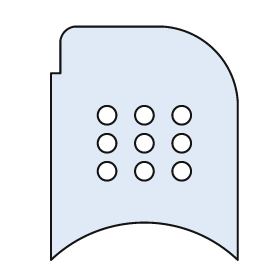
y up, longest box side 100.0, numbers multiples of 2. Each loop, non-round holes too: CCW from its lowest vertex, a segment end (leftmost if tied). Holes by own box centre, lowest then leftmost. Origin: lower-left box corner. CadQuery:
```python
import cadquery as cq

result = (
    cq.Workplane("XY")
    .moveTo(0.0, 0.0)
    .threePointArc((40.0, 16.0), (80.0, 0.0))
    .lineTo(80.0, 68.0)
    .threePointArc((70.0, 90.0), (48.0, 100.0))
    .lineTo(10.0, 100.0)
    .threePointArc((6.0, 98.0), (4.0, 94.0))
    .lineTo(4.0, 80.0)
    .lineTo(0.0, 80.0)
    .close()
    .moveTo(24.0, 38.0)
    .circle(4.0)
    .moveTo(40.0, 38.0)
    .circle(4.0)
    .moveTo(56.0, 38.0)
    .circle(4.0)
    .moveTo(24.0, 50.0)
    .circle(4.0)
    .moveTo(40.0, 50.0)
    .circle(4.0)
    .moveTo(56.0, 50.0)
    .circle(4.0)
    .moveTo(24.0, 62.0)
    .circle(4.0)
    .moveTo(40.0, 62.0)
    .circle(4.0)
    .moveTo(56.0, 62.0)
    .circle(4.0)
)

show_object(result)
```